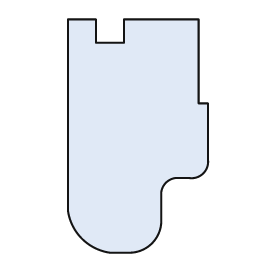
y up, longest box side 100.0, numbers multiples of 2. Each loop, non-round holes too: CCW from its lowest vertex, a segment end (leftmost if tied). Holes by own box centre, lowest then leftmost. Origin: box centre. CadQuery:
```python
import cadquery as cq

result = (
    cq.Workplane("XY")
    .moveTo(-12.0, -50.0)
    .lineTo(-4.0, -50.0)
    .threePointArc((6.0, -46.0), (10.0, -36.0))
    .lineTo(10.0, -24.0)
    .threePointArc((12.0, -20.0), (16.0, -18.0))
    .lineTo(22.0, -18.0)
    .threePointArc((28.0, -16.0), (30.0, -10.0))
    .lineTo(30.0, 14.0)
    .lineTo(26.0, 14.0)
    .lineTo(26.0, 50.0)
    .lineTo(-6.0, 50.0)
    .lineTo(-6.0, 40.0)
    .lineTo(-18.0, 40.0)
    .lineTo(-18.0, 50.0)
    .lineTo(-30.0, 50.0)
    .lineTo(-30.0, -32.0)
    .threePointArc((-24.0, -44.0), (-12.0, -50.0))
    .close()
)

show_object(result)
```